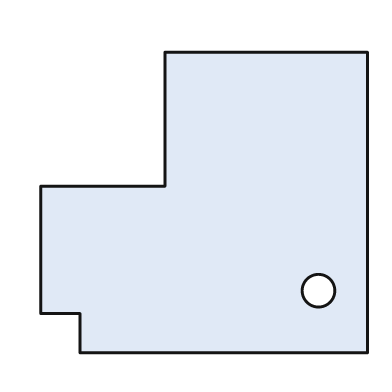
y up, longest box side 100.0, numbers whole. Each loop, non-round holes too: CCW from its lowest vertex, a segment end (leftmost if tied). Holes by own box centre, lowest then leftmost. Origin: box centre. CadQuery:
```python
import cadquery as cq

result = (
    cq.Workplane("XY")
    .moveTo(-38.0, -46.0)
    .lineTo(50.0, -46.0)
    .lineTo(50.0, 46.0)
    .lineTo(-12.0, 46.0)
    .lineTo(-12.0, 5.0)
    .lineTo(-50.0, 5.0)
    .lineTo(-50.0, -34.0)
    .lineTo(-38.0, -34.0)
    .close()
    .moveTo(35.0, -27.0)
    .circle(5.0)
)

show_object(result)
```